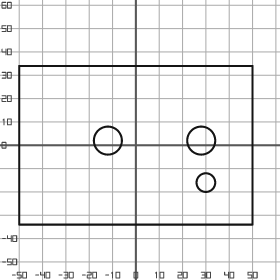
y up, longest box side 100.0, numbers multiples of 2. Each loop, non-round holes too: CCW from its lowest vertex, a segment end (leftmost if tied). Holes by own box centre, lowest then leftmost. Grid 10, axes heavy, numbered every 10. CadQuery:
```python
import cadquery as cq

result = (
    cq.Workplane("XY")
    .moveTo(-50.0, -34.0)
    .lineTo(50.0, -34.0)
    .lineTo(50.0, 34.0)
    .lineTo(-50.0, 34.0)
    .close()
    .moveTo(30.0, -16.0)
    .circle(4.0)
    .moveTo(-12.0, 2.0)
    .circle(6.0)
    .moveTo(28.0, 2.0)
    .circle(6.0)
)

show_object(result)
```